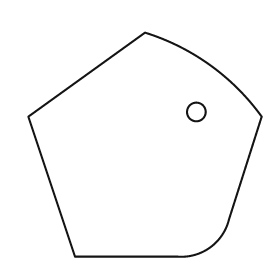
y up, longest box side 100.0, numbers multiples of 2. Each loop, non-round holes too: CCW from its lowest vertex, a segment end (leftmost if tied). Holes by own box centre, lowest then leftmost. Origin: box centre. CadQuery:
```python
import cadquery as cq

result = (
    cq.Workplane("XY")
    .moveTo(-30.0, -48.0)
    .lineTo(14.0, -48.0)
    .threePointArc((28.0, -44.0), (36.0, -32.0))
    .lineTo(50.0, 12.0)
    .threePointArc((28.0, 34.0), (0.0, 48.0))
    .lineTo(-50.0, 12.0)
    .close()
    .moveTo(22.0, 14.0)
    .circle(4.0)
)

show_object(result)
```